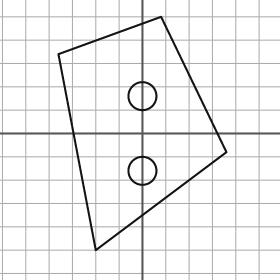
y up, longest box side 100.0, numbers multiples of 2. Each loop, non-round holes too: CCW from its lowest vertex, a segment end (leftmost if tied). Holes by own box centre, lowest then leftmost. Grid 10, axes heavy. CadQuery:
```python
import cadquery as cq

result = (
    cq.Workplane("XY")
    .moveTo(-20.0, -50.0)
    .lineTo(36.0, -8.0)
    .lineTo(8.0, 50.0)
    .lineTo(-36.0, 34.0)
    .close()
    .moveTo(0.0, -16.0)
    .circle(6.0)
    .moveTo(0.0, 16.0)
    .circle(6.0)
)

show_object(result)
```